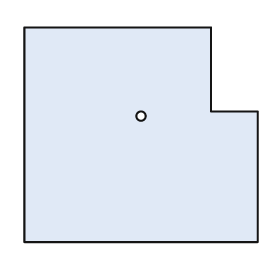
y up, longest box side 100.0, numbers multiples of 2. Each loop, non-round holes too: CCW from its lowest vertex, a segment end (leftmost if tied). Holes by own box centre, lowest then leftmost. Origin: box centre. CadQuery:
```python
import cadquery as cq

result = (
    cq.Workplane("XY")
    .moveTo(-50.0, -46.0)
    .lineTo(50.0, -46.0)
    .lineTo(50.0, 10.0)
    .lineTo(30.0, 10.0)
    .lineTo(30.0, 46.0)
    .lineTo(-50.0, 46.0)
    .close()
    .moveTo(0.0, 8.0)
    .circle(2.0)
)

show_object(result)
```